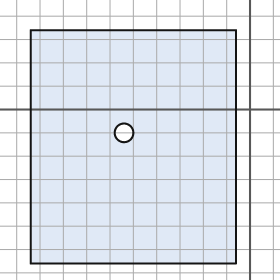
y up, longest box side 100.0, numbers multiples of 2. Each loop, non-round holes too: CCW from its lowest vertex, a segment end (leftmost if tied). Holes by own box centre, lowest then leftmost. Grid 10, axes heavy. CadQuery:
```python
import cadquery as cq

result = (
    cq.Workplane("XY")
    .moveTo(-94.0, -66.0)
    .lineTo(-6.0, -66.0)
    .lineTo(-6.0, 34.0)
    .lineTo(-94.0, 34.0)
    .close()
    .moveTo(-54.0, -10.0)
    .circle(4.0)
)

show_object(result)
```